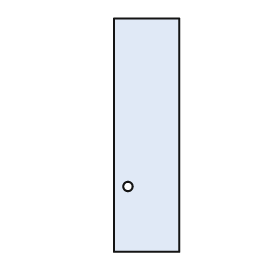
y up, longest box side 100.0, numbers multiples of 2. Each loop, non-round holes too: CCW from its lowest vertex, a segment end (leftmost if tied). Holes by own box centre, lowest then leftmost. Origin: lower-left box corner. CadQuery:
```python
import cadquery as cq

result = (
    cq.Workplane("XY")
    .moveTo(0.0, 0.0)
    .lineTo(28.0, 0.0)
    .lineTo(28.0, 100.0)
    .lineTo(0.0, 100.0)
    .close()
    .moveTo(6.0, 28.0)
    .circle(2.0)
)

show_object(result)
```